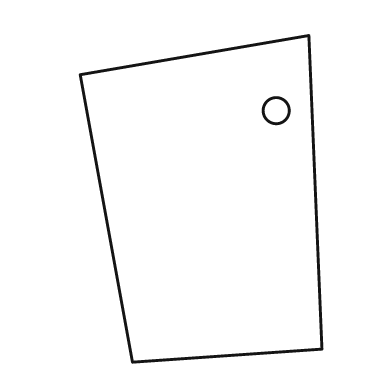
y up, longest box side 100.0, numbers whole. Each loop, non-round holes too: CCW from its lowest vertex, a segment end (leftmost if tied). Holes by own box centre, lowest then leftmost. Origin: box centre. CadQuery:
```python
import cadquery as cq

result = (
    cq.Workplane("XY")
    .moveTo(-21.0, -50.0)
    .lineTo(37.0, -46.0)
    .lineTo(33.0, 50.0)
    .lineTo(-37.0, 38.0)
    .close()
    .moveTo(23.0, 27.0)
    .circle(4.0)
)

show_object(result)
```